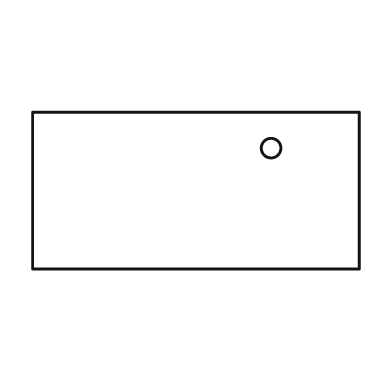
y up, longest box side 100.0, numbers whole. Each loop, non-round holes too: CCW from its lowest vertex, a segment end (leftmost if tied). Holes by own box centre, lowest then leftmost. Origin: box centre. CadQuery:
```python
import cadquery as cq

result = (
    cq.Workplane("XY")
    .moveTo(-50.0, -24.0)
    .lineTo(50.0, -24.0)
    .lineTo(50.0, 24.0)
    .lineTo(-50.0, 24.0)
    .close()
    .moveTo(23.0, 13.0)
    .circle(3.0)
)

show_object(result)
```